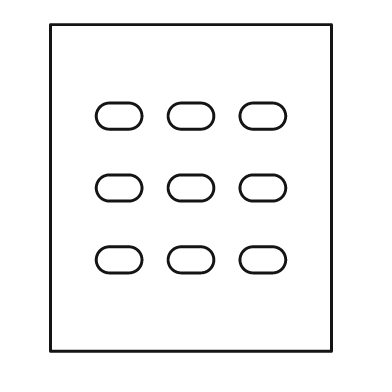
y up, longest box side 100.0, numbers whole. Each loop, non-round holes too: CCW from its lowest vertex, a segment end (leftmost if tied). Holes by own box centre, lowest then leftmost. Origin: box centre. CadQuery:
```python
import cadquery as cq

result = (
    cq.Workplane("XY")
    .moveTo(-43.0, -50.0)
    .lineTo(43.0, -50.0)
    .lineTo(43.0, 50.0)
    .lineTo(-43.0, 50.0)
    .close()
    .moveTo(-25.0, -26.0)
    .lineTo(-19.0, -26.0)
    .threePointArc((-15.0, -22.0), (-19.0, -18.0))
    .lineTo(-25.0, -18.0)
    .threePointArc((-29.0, -22.0), (-25.0, -26.0))
    .close()
    .moveTo(-3.0, -26.0)
    .lineTo(3.0, -26.0)
    .threePointArc((7.0, -22.0), (3.0, -18.0))
    .lineTo(-3.0, -18.0)
    .threePointArc((-7.0, -22.0), (-3.0, -26.0))
    .close()
    .moveTo(19.0, -26.0)
    .lineTo(25.0, -26.0)
    .threePointArc((29.0, -22.0), (25.0, -18.0))
    .lineTo(19.0, -18.0)
    .threePointArc((15.0, -22.0), (19.0, -26.0))
    .close()
    .moveTo(-25.0, -4.0)
    .lineTo(-19.0, -4.0)
    .threePointArc((-15.0, 0.0), (-19.0, 4.0))
    .lineTo(-25.0, 4.0)
    .threePointArc((-29.0, 0.0), (-25.0, -4.0))
    .close()
    .moveTo(-3.0, -4.0)
    .lineTo(3.0, -4.0)
    .threePointArc((7.0, 0.0), (3.0, 4.0))
    .lineTo(-3.0, 4.0)
    .threePointArc((-7.0, 0.0), (-3.0, -4.0))
    .close()
    .moveTo(19.0, -4.0)
    .lineTo(25.0, -4.0)
    .threePointArc((29.0, 0.0), (25.0, 4.0))
    .lineTo(19.0, 4.0)
    .threePointArc((15.0, 0.0), (19.0, -4.0))
    .close()
    .moveTo(-25.0, 18.0)
    .lineTo(-19.0, 18.0)
    .threePointArc((-15.0, 22.0), (-19.0, 26.0))
    .lineTo(-25.0, 26.0)
    .threePointArc((-29.0, 22.0), (-25.0, 18.0))
    .close()
    .moveTo(-3.0, 18.0)
    .lineTo(3.0, 18.0)
    .threePointArc((7.0, 22.0), (3.0, 26.0))
    .lineTo(-3.0, 26.0)
    .threePointArc((-7.0, 22.0), (-3.0, 18.0))
    .close()
    .moveTo(19.0, 18.0)
    .lineTo(25.0, 18.0)
    .threePointArc((29.0, 22.0), (25.0, 26.0))
    .lineTo(19.0, 26.0)
    .threePointArc((15.0, 22.0), (19.0, 18.0))
    .close()
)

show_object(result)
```